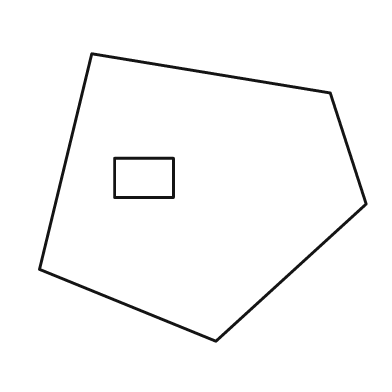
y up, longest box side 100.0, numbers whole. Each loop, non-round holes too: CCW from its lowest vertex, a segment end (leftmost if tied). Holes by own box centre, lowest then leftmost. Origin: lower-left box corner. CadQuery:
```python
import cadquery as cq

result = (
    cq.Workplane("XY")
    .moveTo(54.0, 0.0)
    .lineTo(100.0, 42.0)
    .lineTo(89.0, 76.0)
    .lineTo(16.0, 88.0)
    .lineTo(0.0, 22.0)
    .close()
    .moveTo(23.0, 44.0)
    .lineTo(41.0, 44.0)
    .lineTo(41.0, 56.0)
    .lineTo(23.0, 56.0)
    .close()
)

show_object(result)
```